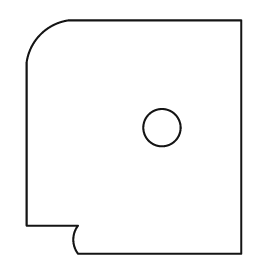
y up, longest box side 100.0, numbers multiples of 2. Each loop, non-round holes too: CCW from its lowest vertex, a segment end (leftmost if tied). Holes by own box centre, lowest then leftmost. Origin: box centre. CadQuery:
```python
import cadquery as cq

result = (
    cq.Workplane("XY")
    .moveTo(-24.0, -50.0)
    .lineTo(46.0, -50.0)
    .lineTo(46.0, 50.0)
    .lineTo(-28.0, 50.0)
    .threePointArc((-40.0, 44.0), (-46.0, 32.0))
    .lineTo(-46.0, -38.0)
    .lineTo(-24.0, -38.0)
    .threePointArc((-26.0, -44.0), (-24.0, -50.0))
    .close()
    .moveTo(12.0, 4.0)
    .circle(8.0)
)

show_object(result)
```